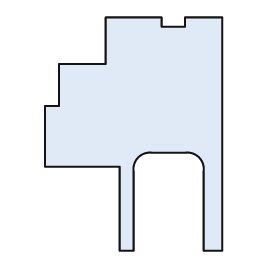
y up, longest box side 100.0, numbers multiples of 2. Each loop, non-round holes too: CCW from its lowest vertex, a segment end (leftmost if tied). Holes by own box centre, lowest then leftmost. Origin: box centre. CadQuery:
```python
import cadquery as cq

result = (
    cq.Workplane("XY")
    .moveTo(-6.0, -50.0)
    .lineTo(0.0, -50.0)
    .lineTo(0.0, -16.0)
    .threePointArc((2.0, -10.0), (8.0, -8.0))
    .lineTo(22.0, -8.0)
    .threePointArc((28.0, -10.0), (30.0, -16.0))
    .lineTo(30.0, -50.0)
    .lineTo(38.0, -50.0)
    .lineTo(38.0, 50.0)
    .lineTo(22.0, 50.0)
    .lineTo(22.0, 46.0)
    .lineTo(12.0, 46.0)
    .lineTo(12.0, 50.0)
    .lineTo(-12.0, 50.0)
    .lineTo(-12.0, 30.0)
    .lineTo(-32.0, 30.0)
    .lineTo(-32.0, 12.0)
    .lineTo(-38.0, 12.0)
    .lineTo(-38.0, -14.0)
    .lineTo(-6.0, -14.0)
    .close()
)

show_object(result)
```